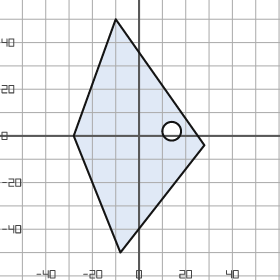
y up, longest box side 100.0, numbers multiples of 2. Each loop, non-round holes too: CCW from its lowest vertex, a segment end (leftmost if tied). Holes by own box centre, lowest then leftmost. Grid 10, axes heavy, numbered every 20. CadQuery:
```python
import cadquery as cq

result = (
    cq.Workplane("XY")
    .moveTo(-8.0, -50.0)
    .lineTo(28.0, -4.0)
    .lineTo(-10.0, 50.0)
    .lineTo(-28.0, 0.0)
    .close()
    .moveTo(14.0, 2.0)
    .circle(4.0)
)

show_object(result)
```